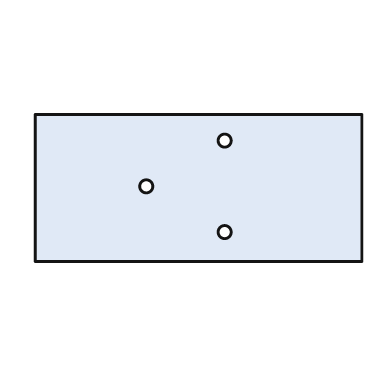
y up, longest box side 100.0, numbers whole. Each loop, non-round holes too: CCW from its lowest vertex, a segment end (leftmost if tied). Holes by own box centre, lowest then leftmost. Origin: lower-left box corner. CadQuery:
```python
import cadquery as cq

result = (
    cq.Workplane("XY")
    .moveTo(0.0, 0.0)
    .lineTo(100.0, 0.0)
    .lineTo(100.0, 45.0)
    .lineTo(0.0, 45.0)
    .close()
    .moveTo(58.0, 9.0)
    .circle(2.0)
    .moveTo(34.0, 23.0)
    .circle(2.0)
    .moveTo(58.0, 37.0)
    .circle(2.0)
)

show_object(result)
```